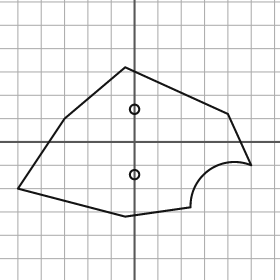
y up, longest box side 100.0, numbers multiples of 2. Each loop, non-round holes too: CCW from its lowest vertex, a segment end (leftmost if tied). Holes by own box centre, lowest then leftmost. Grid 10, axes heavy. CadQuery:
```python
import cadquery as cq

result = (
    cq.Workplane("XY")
    .moveTo(-4.0, -32.0)
    .lineTo(24.0, -28.0)
    .threePointArc((32.0, -12.0), (50.0, -10.0))
    .lineTo(40.0, 12.0)
    .lineTo(-4.0, 32.0)
    .lineTo(-30.0, 10.0)
    .lineTo(-50.0, -20.0)
    .close()
    .moveTo(0.0, -14.0)
    .circle(2.0)
    .moveTo(0.0, 14.0)
    .circle(2.0)
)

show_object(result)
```